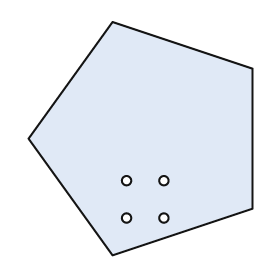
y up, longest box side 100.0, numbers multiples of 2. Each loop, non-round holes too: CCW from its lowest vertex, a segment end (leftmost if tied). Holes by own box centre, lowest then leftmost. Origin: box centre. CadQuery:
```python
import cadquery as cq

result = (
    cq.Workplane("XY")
    .moveTo(-12.0, -50.0)
    .lineTo(48.0, -30.0)
    .lineTo(48.0, 30.0)
    .lineTo(-12.0, 50.0)
    .lineTo(-48.0, 0.0)
    .close()
    .moveTo(-6.0, -34.0)
    .circle(2.0)
    .moveTo(10.0, -34.0)
    .circle(2.0)
    .moveTo(-6.0, -18.0)
    .circle(2.0)
    .moveTo(10.0, -18.0)
    .circle(2.0)
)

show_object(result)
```